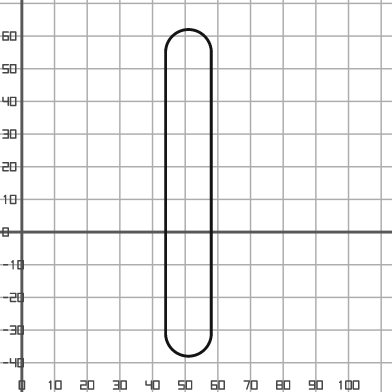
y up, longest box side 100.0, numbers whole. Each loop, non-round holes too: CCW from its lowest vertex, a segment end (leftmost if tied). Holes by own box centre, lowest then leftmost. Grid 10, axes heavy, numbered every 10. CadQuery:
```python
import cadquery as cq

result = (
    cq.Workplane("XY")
    .moveTo(44.0, -31.0)
    .threePointArc((51.0, -38.0), (58.0, -31.0))
    .lineTo(58.0, 55.0)
    .threePointArc((51.0, 62.0), (44.0, 55.0))
    .close()
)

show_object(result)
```